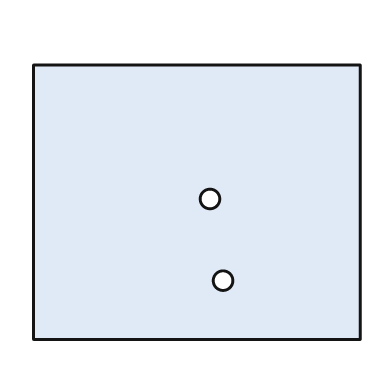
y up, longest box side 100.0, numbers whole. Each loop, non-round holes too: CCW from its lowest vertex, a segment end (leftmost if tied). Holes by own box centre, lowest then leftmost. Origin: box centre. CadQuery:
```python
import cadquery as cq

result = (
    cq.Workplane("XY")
    .moveTo(-50.0, -42.0)
    .lineTo(50.0, -42.0)
    .lineTo(50.0, 42.0)
    .lineTo(-50.0, 42.0)
    .close()
    .moveTo(8.0, -24.0)
    .circle(3.0)
    .moveTo(4.0, 1.0)
    .circle(3.0)
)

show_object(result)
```